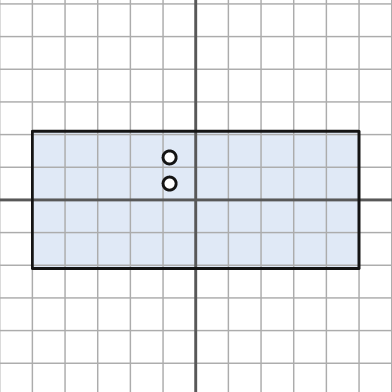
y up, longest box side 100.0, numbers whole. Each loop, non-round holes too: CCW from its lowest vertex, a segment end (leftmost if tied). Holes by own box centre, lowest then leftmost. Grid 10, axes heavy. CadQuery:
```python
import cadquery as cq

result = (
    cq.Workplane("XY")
    .moveTo(-50.0, -21.0)
    .lineTo(50.0, -21.0)
    .lineTo(50.0, 21.0)
    .lineTo(-50.0, 21.0)
    .close()
    .moveTo(-8.0, 5.0)
    .circle(2.0)
    .moveTo(-8.0, 13.0)
    .circle(2.0)
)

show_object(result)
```